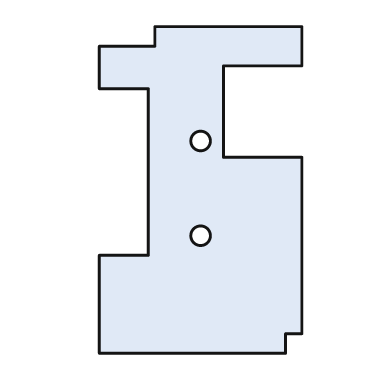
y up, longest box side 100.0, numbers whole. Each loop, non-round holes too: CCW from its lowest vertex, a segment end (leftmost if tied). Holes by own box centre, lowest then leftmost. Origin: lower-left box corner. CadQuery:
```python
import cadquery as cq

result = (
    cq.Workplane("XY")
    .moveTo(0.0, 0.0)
    .lineTo(57.0, 0.0)
    .lineTo(57.0, 6.0)
    .lineTo(62.0, 6.0)
    .lineTo(62.0, 60.0)
    .lineTo(38.0, 60.0)
    .lineTo(38.0, 88.0)
    .lineTo(62.0, 88.0)
    .lineTo(62.0, 100.0)
    .lineTo(17.0, 100.0)
    .lineTo(17.0, 94.0)
    .lineTo(0.0, 94.0)
    .lineTo(0.0, 81.0)
    .lineTo(15.0, 81.0)
    .lineTo(15.0, 30.0)
    .lineTo(0.0, 30.0)
    .close()
    .moveTo(31.0, 36.0)
    .circle(3.0)
    .moveTo(31.0, 65.0)
    .circle(3.0)
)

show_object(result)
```